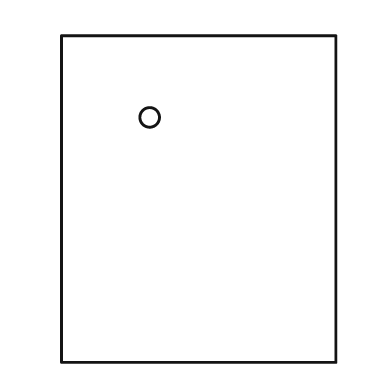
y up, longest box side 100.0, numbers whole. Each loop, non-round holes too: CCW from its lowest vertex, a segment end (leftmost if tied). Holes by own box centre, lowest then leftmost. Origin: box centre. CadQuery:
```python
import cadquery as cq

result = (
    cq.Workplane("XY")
    .moveTo(-42.0, -50.0)
    .lineTo(42.0, -50.0)
    .lineTo(42.0, 50.0)
    .lineTo(-42.0, 50.0)
    .close()
    .moveTo(-15.0, 25.0)
    .circle(3.0)
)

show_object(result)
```